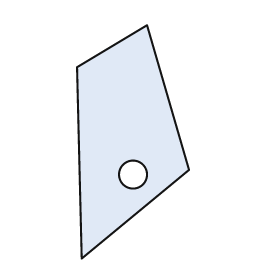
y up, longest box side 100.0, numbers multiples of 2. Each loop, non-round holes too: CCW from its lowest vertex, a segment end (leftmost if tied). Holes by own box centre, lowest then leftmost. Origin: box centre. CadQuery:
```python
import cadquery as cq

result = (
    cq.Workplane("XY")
    .moveTo(-22.0, -50.0)
    .lineTo(24.0, -12.0)
    .lineTo(6.0, 50.0)
    .lineTo(-24.0, 32.0)
    .close()
    .moveTo(0.0, -14.0)
    .circle(6.0)
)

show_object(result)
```